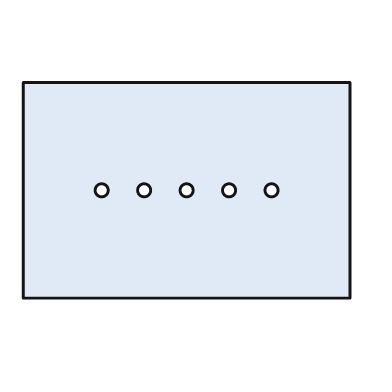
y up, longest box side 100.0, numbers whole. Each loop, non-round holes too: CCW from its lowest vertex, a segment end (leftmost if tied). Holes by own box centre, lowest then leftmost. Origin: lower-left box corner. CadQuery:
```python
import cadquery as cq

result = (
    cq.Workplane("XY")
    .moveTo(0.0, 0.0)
    .lineTo(100.0, 0.0)
    .lineTo(100.0, 66.0)
    .lineTo(0.0, 66.0)
    .close()
    .moveTo(24.0, 33.0)
    .circle(2.0)
    .moveTo(37.0, 33.0)
    .circle(2.0)
    .moveTo(50.0, 33.0)
    .circle(2.0)
    .moveTo(63.0, 33.0)
    .circle(2.0)
    .moveTo(76.0, 33.0)
    .circle(2.0)
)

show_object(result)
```